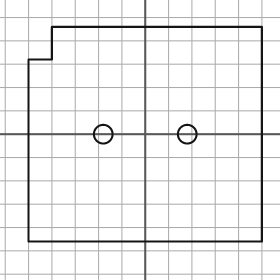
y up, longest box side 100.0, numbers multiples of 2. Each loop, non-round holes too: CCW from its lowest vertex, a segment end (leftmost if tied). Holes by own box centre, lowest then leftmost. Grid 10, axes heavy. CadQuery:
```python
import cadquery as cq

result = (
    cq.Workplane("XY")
    .moveTo(-50.0, -46.0)
    .lineTo(50.0, -46.0)
    .lineTo(50.0, 46.0)
    .lineTo(-40.0, 46.0)
    .lineTo(-40.0, 32.0)
    .lineTo(-50.0, 32.0)
    .close()
    .moveTo(-18.0, 0.0)
    .circle(4.0)
    .moveTo(18.0, 0.0)
    .circle(4.0)
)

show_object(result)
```